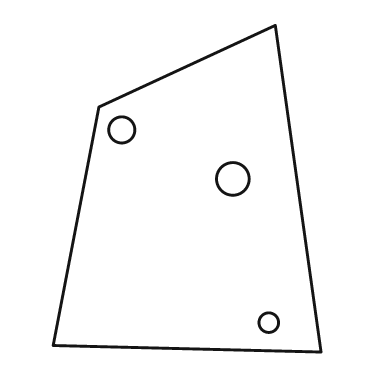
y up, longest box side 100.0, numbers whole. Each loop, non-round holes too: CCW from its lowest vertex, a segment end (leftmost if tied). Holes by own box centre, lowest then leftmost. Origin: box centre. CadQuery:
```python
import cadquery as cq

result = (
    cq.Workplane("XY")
    .moveTo(41.0, -50.0)
    .lineTo(27.0, 50.0)
    .lineTo(-27.0, 25.0)
    .lineTo(-41.0, -48.0)
    .close()
    .moveTo(25.0, -41.0)
    .circle(3.0)
    .moveTo(14.0, 3.0)
    .circle(5.0)
    .moveTo(-20.0, 18.0)
    .circle(4.0)
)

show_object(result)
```